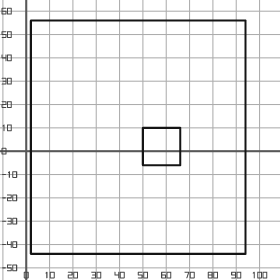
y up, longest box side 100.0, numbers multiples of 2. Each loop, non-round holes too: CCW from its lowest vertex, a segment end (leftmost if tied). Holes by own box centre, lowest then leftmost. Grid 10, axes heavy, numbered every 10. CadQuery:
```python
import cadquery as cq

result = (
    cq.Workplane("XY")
    .moveTo(2.0, -44.0)
    .lineTo(94.0, -44.0)
    .lineTo(94.0, 56.0)
    .lineTo(2.0, 56.0)
    .close()
    .moveTo(50.0, -6.0)
    .lineTo(66.0, -6.0)
    .lineTo(66.0, 10.0)
    .lineTo(50.0, 10.0)
    .close()
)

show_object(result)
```